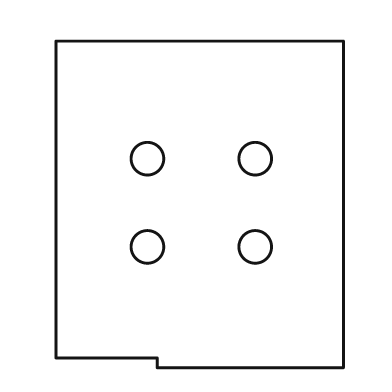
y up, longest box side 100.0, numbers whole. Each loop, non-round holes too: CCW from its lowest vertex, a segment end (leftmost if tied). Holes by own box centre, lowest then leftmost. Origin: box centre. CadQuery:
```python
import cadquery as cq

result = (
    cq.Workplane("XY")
    .moveTo(-13.0, -50.0)
    .lineTo(44.0, -50.0)
    .lineTo(44.0, 50.0)
    .lineTo(-44.0, 50.0)
    .lineTo(-44.0, -47.0)
    .lineTo(-13.0, -47.0)
    .close()
    .moveTo(-16.0, -13.0)
    .circle(5.0)
    .moveTo(17.0, -13.0)
    .circle(5.0)
    .moveTo(-16.0, 14.0)
    .circle(5.0)
    .moveTo(17.0, 14.0)
    .circle(5.0)
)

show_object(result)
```